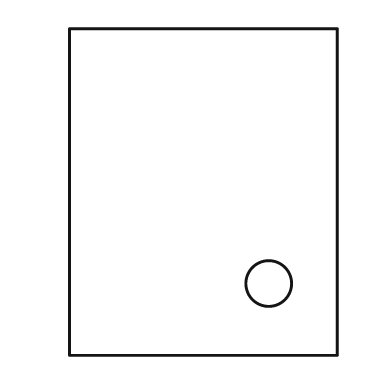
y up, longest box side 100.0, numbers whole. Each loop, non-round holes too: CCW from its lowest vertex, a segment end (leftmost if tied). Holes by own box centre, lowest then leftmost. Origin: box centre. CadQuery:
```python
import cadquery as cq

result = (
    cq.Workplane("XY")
    .moveTo(-41.0, -50.0)
    .lineTo(41.0, -50.0)
    .lineTo(41.0, 50.0)
    .lineTo(-41.0, 50.0)
    .close()
    .moveTo(20.0, -28.0)
    .circle(7.0)
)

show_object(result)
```